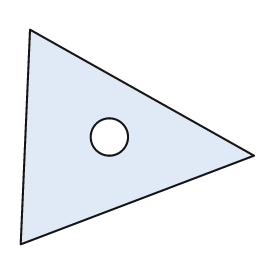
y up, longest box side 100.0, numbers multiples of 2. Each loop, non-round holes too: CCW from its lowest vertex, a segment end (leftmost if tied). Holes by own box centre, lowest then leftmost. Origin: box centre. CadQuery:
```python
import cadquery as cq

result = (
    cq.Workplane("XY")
    .moveTo(-50.0, -46.0)
    .lineTo(50.0, -8.0)
    .lineTo(-46.0, 46.0)
    .close()
    .moveTo(-12.0, 0.0)
    .circle(8.0)
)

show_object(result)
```